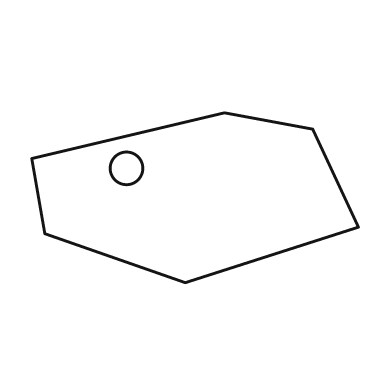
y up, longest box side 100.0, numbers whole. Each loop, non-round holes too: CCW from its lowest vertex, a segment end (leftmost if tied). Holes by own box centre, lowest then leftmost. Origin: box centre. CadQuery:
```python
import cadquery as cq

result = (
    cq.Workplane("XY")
    .moveTo(-3.0, -26.0)
    .lineTo(50.0, -9.0)
    .lineTo(36.0, 21.0)
    .lineTo(9.0, 26.0)
    .lineTo(-50.0, 12.0)
    .lineTo(-46.0, -11.0)
    .close()
    .moveTo(-21.0, 9.0)
    .circle(5.0)
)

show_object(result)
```